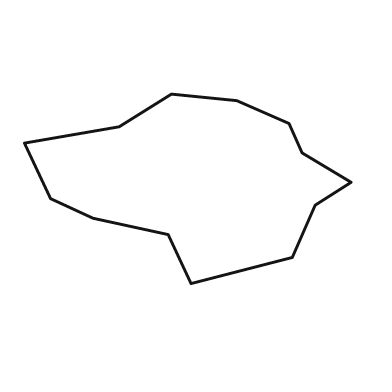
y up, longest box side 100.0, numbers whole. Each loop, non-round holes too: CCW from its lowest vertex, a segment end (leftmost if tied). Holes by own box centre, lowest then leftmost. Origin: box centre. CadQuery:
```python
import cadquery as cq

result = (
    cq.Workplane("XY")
    .moveTo(1.0, -29.0)
    .lineTo(32.0, -21.0)
    .lineTo(39.0, -5.0)
    .lineTo(50.0, 2.0)
    .lineTo(35.0, 11.0)
    .lineTo(31.0, 20.0)
    .lineTo(15.0, 27.0)
    .lineTo(-5.0, 29.0)
    .lineTo(-21.0, 19.0)
    .lineTo(-50.0, 14.0)
    .lineTo(-42.0, -3.0)
    .lineTo(-29.0, -9.0)
    .lineTo(-6.0, -14.0)
    .close()
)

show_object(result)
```